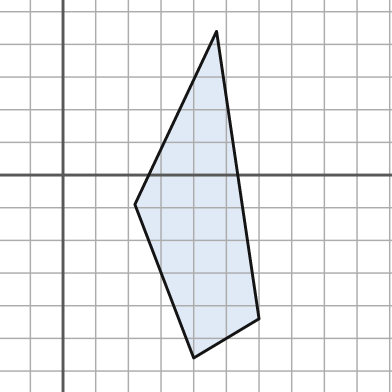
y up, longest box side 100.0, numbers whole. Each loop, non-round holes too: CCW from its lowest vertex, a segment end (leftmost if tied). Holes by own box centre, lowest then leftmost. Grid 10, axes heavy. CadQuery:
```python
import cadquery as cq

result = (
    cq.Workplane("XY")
    .moveTo(40.0, -56.0)
    .lineTo(60.0, -44.0)
    .lineTo(47.0, 44.0)
    .lineTo(22.0, -9.0)
    .close()
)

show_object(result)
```